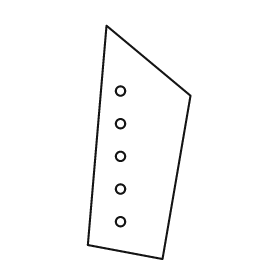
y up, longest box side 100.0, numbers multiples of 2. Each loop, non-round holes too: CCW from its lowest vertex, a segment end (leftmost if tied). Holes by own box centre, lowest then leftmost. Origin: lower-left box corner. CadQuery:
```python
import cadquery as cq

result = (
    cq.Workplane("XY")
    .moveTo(32.0, 0.0)
    .lineTo(44.0, 70.0)
    .lineTo(8.0, 100.0)
    .lineTo(0.0, 6.0)
    .close()
    .moveTo(14.0, 16.0)
    .circle(2.0)
    .moveTo(14.0, 30.0)
    .circle(2.0)
    .moveTo(14.0, 44.0)
    .circle(2.0)
    .moveTo(14.0, 58.0)
    .circle(2.0)
    .moveTo(14.0, 72.0)
    .circle(2.0)
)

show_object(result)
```